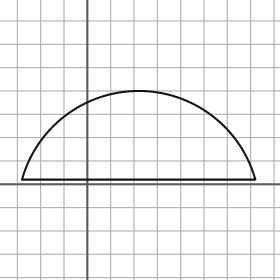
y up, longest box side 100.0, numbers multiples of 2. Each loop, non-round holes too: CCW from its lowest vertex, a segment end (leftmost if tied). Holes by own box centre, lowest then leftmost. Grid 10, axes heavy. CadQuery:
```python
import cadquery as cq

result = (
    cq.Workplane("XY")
    .moveTo(-28.0, 2.0)
    .lineTo(72.0, 2.0)
    .threePointArc((22.0, 40.0), (-28.0, 2.0))
    .close()
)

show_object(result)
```